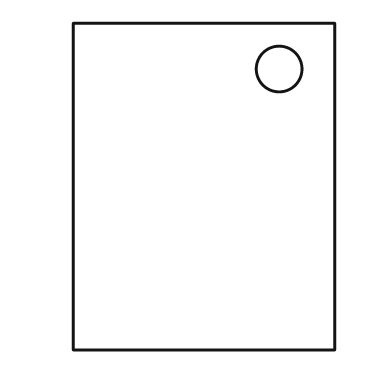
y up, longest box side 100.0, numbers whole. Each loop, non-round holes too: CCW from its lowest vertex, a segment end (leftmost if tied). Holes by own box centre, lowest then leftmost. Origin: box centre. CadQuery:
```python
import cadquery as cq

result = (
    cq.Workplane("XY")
    .moveTo(-40.0, -50.0)
    .lineTo(40.0, -50.0)
    .lineTo(40.0, 50.0)
    .lineTo(-40.0, 50.0)
    .close()
    .moveTo(23.0, 36.0)
    .circle(7.0)
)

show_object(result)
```